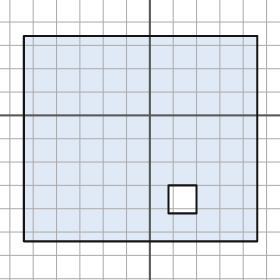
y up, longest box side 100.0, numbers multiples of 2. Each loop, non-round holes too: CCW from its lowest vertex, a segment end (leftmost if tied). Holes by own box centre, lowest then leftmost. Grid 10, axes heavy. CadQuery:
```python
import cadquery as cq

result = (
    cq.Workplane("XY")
    .moveTo(-54.0, -54.0)
    .lineTo(46.0, -54.0)
    .lineTo(46.0, 34.0)
    .lineTo(-54.0, 34.0)
    .close()
    .moveTo(8.0, -42.0)
    .lineTo(20.0, -42.0)
    .lineTo(20.0, -30.0)
    .lineTo(8.0, -30.0)
    .close()
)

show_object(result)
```